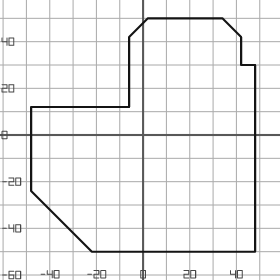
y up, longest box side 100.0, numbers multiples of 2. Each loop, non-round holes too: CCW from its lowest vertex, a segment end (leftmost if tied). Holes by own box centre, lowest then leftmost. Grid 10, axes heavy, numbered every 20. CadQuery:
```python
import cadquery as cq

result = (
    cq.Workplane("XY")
    .moveTo(-22.0, -50.0)
    .lineTo(48.0, -50.0)
    .lineTo(48.0, 30.0)
    .lineTo(42.0, 30.0)
    .lineTo(42.0, 42.0)
    .lineTo(34.0, 50.0)
    .lineTo(2.0, 50.0)
    .lineTo(-6.0, 42.0)
    .lineTo(-6.0, 12.0)
    .lineTo(-48.0, 12.0)
    .lineTo(-48.0, -24.0)
    .close()
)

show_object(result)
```